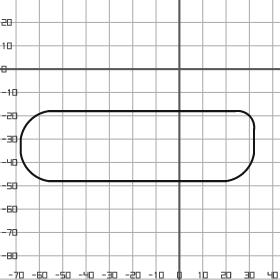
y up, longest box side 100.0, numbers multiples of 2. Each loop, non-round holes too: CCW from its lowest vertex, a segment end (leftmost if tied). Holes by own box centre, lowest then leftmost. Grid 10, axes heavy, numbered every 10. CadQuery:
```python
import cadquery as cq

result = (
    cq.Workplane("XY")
    .moveTo(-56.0, -48.0)
    .lineTo(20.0, -48.0)
    .threePointArc((28.0, -44.0), (32.0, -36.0))
    .lineTo(32.0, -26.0)
    .threePointArc((30.0, -20.0), (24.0, -18.0))
    .lineTo(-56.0, -18.0)
    .threePointArc((-64.0, -22.0), (-68.0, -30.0))
    .lineTo(-68.0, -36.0)
    .threePointArc((-64.0, -44.0), (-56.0, -48.0))
    .close()
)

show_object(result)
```